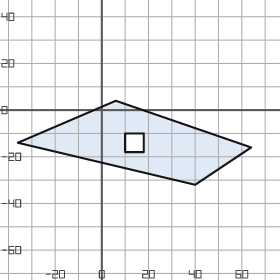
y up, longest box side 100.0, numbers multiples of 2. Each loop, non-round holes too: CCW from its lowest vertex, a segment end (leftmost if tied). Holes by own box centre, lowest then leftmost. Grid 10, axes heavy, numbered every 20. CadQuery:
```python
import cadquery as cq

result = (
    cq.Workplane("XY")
    .moveTo(40.0, -32.0)
    .lineTo(64.0, -16.0)
    .lineTo(6.0, 4.0)
    .lineTo(-36.0, -14.0)
    .close()
    .moveTo(10.0, -18.0)
    .lineTo(18.0, -18.0)
    .lineTo(18.0, -10.0)
    .lineTo(10.0, -10.0)
    .close()
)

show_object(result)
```